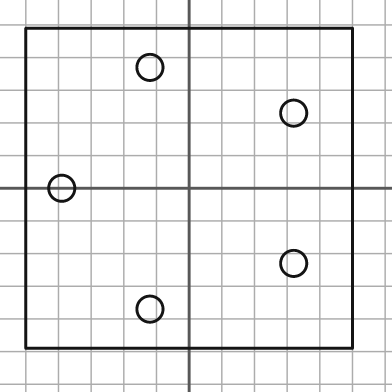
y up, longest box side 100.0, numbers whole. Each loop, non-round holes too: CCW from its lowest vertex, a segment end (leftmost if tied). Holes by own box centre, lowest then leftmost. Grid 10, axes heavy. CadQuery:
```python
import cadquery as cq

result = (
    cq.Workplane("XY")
    .moveTo(-50.0, -49.0)
    .lineTo(50.0, -49.0)
    .lineTo(50.0, 49.0)
    .lineTo(-50.0, 49.0)
    .close()
    .moveTo(-12.0, -37.0)
    .circle(4.0)
    .moveTo(32.0, -23.0)
    .circle(4.0)
    .moveTo(-39.0, 0.0)
    .circle(4.0)
    .moveTo(32.0, 23.0)
    .circle(4.0)
    .moveTo(-12.0, 37.0)
    .circle(4.0)
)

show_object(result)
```